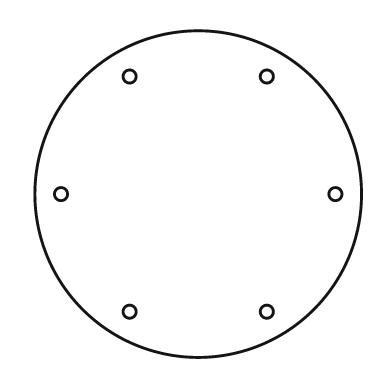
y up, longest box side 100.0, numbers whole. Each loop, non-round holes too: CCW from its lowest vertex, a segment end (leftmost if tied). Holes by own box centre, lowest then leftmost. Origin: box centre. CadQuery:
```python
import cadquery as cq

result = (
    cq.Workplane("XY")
    .moveTo(0.0, 0.0)
    .circle(50.0)
    .moveTo(-21.0, -36.0)
    .circle(2.0)
    .moveTo(21.0, -36.0)
    .circle(2.0)
    .moveTo(-42.0, 0.0)
    .circle(2.0)
    .moveTo(42.0, 0.0)
    .circle(2.0)
    .moveTo(-21.0, 36.0)
    .circle(2.0)
    .moveTo(21.0, 36.0)
    .circle(2.0)
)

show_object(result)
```